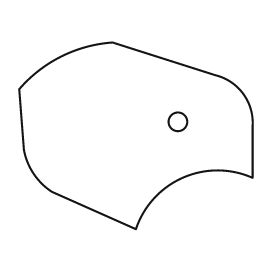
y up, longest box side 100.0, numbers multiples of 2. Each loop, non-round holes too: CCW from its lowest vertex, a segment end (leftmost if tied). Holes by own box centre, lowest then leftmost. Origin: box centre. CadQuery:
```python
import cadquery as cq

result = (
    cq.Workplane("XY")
    .moveTo(0.0, -40.0)
    .threePointArc((20.0, -18.0), (50.0, -18.0))
    .lineTo(50.0, 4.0)
    .threePointArc((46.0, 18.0), (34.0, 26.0))
    .lineTo(-10.0, 40.0)
    .threePointArc((-32.0, 34.0), (-50.0, 20.0))
    .lineTo(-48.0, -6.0)
    .threePointArc((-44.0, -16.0), (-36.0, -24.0))
    .close()
    .moveTo(18.0, 6.0)
    .circle(4.0)
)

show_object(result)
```